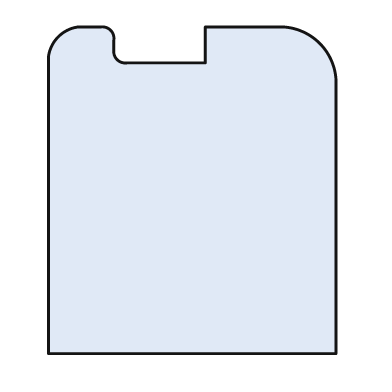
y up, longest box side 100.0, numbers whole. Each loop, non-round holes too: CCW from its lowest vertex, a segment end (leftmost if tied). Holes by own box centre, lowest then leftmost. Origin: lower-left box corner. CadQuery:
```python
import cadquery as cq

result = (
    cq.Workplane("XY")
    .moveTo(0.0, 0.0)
    .lineTo(88.0, 0.0)
    .lineTo(88.0, 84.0)
    .threePointArc((83.0, 95.0), (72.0, 100.0))
    .lineTo(48.0, 100.0)
    .lineTo(48.0, 89.0)
    .lineTo(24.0, 89.0)
    .threePointArc((21.0, 90.0), (20.0, 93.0))
    .lineTo(20.0, 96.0)
    .threePointArc((19.0, 99.0), (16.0, 100.0))
    .lineTo(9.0, 100.0)
    .threePointArc((3.0, 97.0), (0.0, 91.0))
    .close()
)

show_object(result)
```